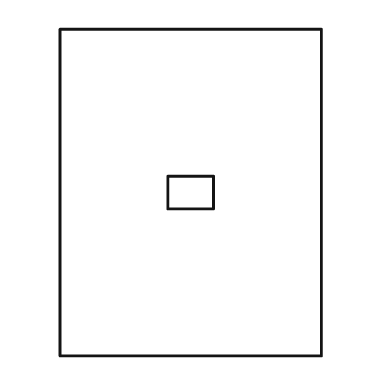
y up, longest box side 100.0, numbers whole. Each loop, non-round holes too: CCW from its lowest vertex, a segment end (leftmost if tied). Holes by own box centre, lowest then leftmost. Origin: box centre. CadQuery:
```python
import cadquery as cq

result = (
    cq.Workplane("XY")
    .moveTo(-40.0, -50.0)
    .lineTo(40.0, -50.0)
    .lineTo(40.0, 50.0)
    .lineTo(-40.0, 50.0)
    .close()
    .moveTo(-7.0, -5.0)
    .lineTo(7.0, -5.0)
    .lineTo(7.0, 5.0)
    .lineTo(-7.0, 5.0)
    .close()
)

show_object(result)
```